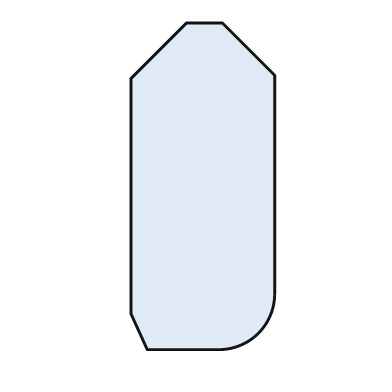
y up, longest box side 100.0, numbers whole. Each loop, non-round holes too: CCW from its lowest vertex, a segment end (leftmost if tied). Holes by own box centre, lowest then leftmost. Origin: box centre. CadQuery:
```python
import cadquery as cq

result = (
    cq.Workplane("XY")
    .moveTo(-17.0, -50.0)
    .lineTo(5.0, -50.0)
    .threePointArc((17.0, -45.0), (22.0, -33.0))
    .lineTo(22.0, 34.0)
    .lineTo(6.0, 50.0)
    .lineTo(-5.0, 50.0)
    .lineTo(-22.0, 33.0)
    .lineTo(-22.0, -39.0)
    .close()
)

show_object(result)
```